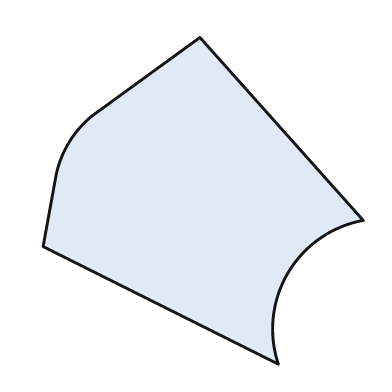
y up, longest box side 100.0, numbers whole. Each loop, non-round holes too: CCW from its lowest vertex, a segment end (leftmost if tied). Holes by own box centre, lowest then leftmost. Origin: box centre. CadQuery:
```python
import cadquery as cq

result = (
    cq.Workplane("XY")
    .moveTo(23.0, -50.0)
    .threePointArc((26.0, -22.0), (49.0, -6.0))
    .lineTo(-1.0, 50.0)
    .lineTo(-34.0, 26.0)
    .threePointArc((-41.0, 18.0), (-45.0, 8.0))
    .lineTo(-49.0, -14.0)
    .close()
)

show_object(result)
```